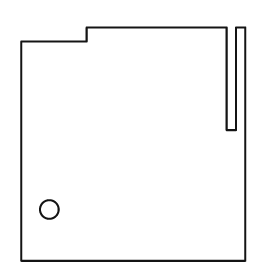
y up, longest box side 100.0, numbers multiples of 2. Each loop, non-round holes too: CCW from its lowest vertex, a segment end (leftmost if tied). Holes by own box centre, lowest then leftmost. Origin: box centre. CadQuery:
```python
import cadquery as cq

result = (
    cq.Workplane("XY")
    .moveTo(-48.0, -50.0)
    .lineTo(48.0, -50.0)
    .lineTo(48.0, 50.0)
    .lineTo(44.0, 50.0)
    .lineTo(44.0, 6.0)
    .lineTo(40.0, 6.0)
    .lineTo(40.0, 50.0)
    .lineTo(-20.0, 50.0)
    .lineTo(-20.0, 44.0)
    .lineTo(-48.0, 44.0)
    .close()
    .moveTo(-36.0, -28.0)
    .circle(4.0)
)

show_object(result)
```